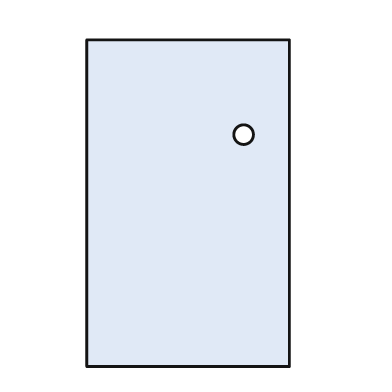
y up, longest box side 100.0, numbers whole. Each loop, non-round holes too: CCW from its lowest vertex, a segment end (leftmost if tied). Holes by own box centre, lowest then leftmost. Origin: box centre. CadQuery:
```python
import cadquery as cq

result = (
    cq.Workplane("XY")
    .moveTo(-31.0, -50.0)
    .lineTo(31.0, -50.0)
    .lineTo(31.0, 50.0)
    .lineTo(-31.0, 50.0)
    .close()
    .moveTo(17.0, 21.0)
    .circle(3.0)
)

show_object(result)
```